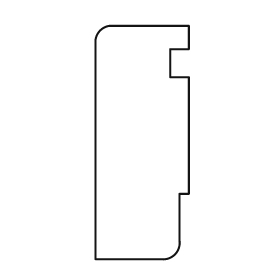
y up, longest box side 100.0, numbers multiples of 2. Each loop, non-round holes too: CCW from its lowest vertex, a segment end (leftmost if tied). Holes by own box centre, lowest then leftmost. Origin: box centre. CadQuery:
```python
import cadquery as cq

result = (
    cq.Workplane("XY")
    .moveTo(-20.0, -50.0)
    .lineTo(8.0, -50.0)
    .threePointArc((14.0, -48.0), (16.0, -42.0))
    .lineTo(16.0, -22.0)
    .lineTo(20.0, -22.0)
    .lineTo(20.0, 28.0)
    .lineTo(12.0, 28.0)
    .lineTo(12.0, 40.0)
    .lineTo(20.0, 40.0)
    .lineTo(20.0, 50.0)
    .lineTo(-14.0, 50.0)
    .threePointArc((-18.0, 48.0), (-20.0, 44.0))
    .close()
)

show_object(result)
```